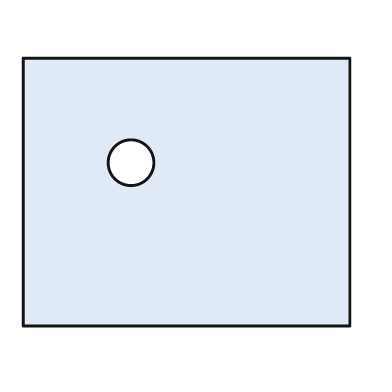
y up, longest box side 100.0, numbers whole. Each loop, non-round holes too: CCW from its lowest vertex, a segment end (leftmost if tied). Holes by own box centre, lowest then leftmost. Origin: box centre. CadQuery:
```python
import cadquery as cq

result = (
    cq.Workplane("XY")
    .moveTo(-50.0, -41.0)
    .lineTo(50.0, -41.0)
    .lineTo(50.0, 41.0)
    .lineTo(-50.0, 41.0)
    .close()
    .moveTo(-17.0, 9.0)
    .circle(7.0)
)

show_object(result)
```